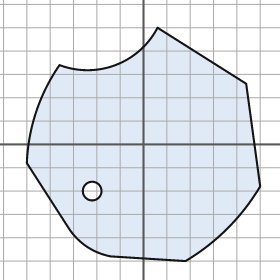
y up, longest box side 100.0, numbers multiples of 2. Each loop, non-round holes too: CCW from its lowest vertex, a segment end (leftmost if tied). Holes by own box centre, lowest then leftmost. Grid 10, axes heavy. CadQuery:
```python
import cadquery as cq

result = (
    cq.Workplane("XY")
    .moveTo(18.0, -50.0)
    .threePointArc((36.0, -36.0), (50.0, -18.0))
    .lineTo(44.0, 26.0)
    .lineTo(6.0, 50.0)
    .threePointArc((-12.0, 34.0), (-36.0, 34.0))
    .threePointArc((-46.0, 14.0), (-50.0, -8.0))
    .lineTo(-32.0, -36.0)
    .threePointArc((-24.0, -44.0), (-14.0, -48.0))
    .close()
    .moveTo(-22.0, -20.0)
    .circle(4.0)
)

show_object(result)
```